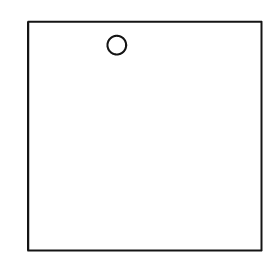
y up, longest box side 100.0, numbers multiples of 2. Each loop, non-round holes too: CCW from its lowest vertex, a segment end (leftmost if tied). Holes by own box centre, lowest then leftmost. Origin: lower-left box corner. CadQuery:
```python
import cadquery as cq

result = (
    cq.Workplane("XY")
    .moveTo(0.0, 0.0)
    .lineTo(100.0, 0.0)
    .lineTo(100.0, 98.0)
    .lineTo(0.0, 98.0)
    .close()
    .moveTo(38.0, 88.0)
    .circle(4.0)
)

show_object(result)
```